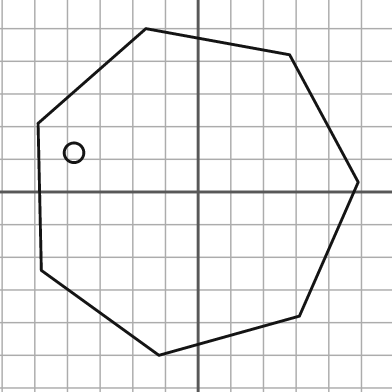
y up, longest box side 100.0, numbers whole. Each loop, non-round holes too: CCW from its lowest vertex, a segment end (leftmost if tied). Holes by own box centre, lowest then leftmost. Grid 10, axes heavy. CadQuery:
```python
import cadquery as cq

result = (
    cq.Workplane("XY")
    .moveTo(-12.0, -50.0)
    .lineTo(31.0, -38.0)
    .lineTo(49.0, 3.0)
    .lineTo(28.0, 42.0)
    .lineTo(-16.0, 50.0)
    .lineTo(-49.0, 21.0)
    .lineTo(-48.0, -24.0)
    .close()
    .moveTo(-38.0, 12.0)
    .circle(3.0)
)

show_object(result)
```